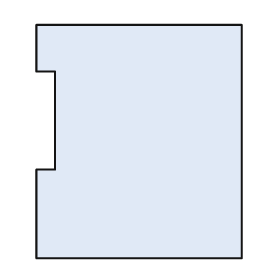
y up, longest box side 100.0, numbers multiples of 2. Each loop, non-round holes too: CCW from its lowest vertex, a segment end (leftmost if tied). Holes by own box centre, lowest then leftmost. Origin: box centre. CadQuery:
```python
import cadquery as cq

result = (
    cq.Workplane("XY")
    .moveTo(-44.0, -50.0)
    .lineTo(44.0, -50.0)
    .lineTo(44.0, 50.0)
    .lineTo(-44.0, 50.0)
    .lineTo(-44.0, 30.0)
    .lineTo(-36.0, 30.0)
    .lineTo(-36.0, -12.0)
    .lineTo(-44.0, -12.0)
    .close()
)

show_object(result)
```